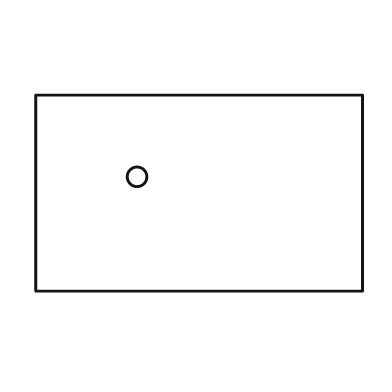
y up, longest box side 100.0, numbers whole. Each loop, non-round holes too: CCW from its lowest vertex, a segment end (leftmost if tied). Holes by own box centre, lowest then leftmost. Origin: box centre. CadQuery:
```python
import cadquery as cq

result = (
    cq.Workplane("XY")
    .moveTo(-50.0, -30.0)
    .lineTo(50.0, -30.0)
    .lineTo(50.0, 30.0)
    .lineTo(-50.0, 30.0)
    .close()
    .moveTo(-19.0, 5.0)
    .circle(3.0)
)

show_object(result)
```